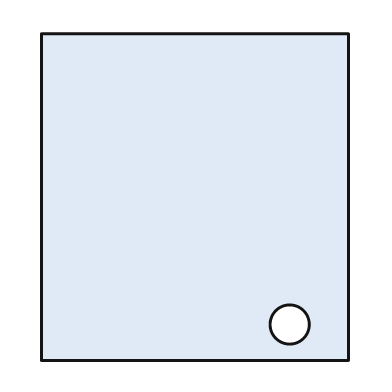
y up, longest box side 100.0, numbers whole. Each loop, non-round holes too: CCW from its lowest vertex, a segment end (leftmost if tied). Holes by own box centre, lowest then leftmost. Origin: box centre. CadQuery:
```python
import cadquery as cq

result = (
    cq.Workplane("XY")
    .moveTo(-47.0, -50.0)
    .lineTo(47.0, -50.0)
    .lineTo(47.0, 50.0)
    .lineTo(-47.0, 50.0)
    .close()
    .moveTo(29.0, -39.0)
    .circle(6.0)
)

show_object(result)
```